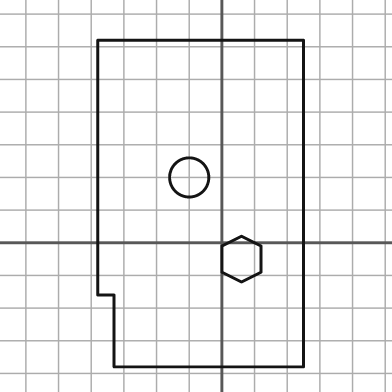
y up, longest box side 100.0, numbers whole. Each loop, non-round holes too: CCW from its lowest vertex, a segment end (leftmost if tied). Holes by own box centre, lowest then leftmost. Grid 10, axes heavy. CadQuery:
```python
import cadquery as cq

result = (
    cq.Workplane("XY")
    .moveTo(-33.0, -38.0)
    .lineTo(25.0, -38.0)
    .lineTo(25.0, 62.0)
    .lineTo(-38.0, 62.0)
    .lineTo(-38.0, -16.0)
    .lineTo(-33.0, -16.0)
    .close()
    .moveTo(6.0, -12.0)
    .lineTo(12.0, -9.0)
    .lineTo(12.0, -1.0)
    .lineTo(6.0, 2.0)
    .lineTo(0.0, -1.0)
    .lineTo(0.0, -9.0)
    .close()
    .moveTo(-10.0, 20.0)
    .circle(6.0)
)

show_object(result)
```